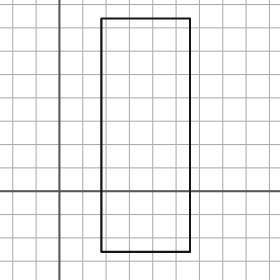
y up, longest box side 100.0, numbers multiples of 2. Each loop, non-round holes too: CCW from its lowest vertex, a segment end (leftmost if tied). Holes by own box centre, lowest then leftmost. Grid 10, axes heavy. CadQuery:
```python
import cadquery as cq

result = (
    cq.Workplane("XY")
    .moveTo(18.0, -26.0)
    .lineTo(56.0, -26.0)
    .lineTo(56.0, 74.0)
    .lineTo(18.0, 74.0)
    .close()
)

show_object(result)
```